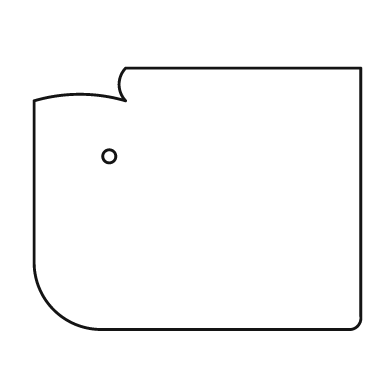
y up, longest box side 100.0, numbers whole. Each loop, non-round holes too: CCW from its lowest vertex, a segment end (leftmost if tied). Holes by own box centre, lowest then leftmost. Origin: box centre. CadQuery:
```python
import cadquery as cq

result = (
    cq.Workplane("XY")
    .moveTo(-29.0, -40.0)
    .lineTo(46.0, -40.0)
    .threePointArc((49.0, -39.0), (50.0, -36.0))
    .lineTo(50.0, 40.0)
    .lineTo(-22.0, 40.0)
    .threePointArc((-24.0, 35.0), (-22.0, 30.0))
    .threePointArc((-36.0, 32.0), (-50.0, 30.0))
    .lineTo(-50.0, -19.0)
    .threePointArc((-44.0, -34.0), (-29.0, -40.0))
    .close()
    .moveTo(-27.0, 13.0)
    .circle(2.0)
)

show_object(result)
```